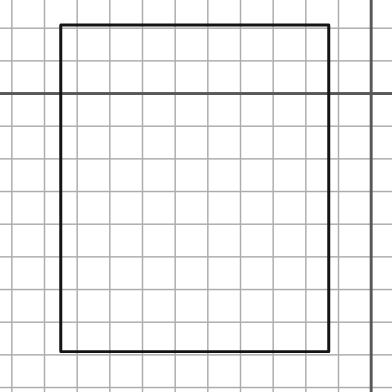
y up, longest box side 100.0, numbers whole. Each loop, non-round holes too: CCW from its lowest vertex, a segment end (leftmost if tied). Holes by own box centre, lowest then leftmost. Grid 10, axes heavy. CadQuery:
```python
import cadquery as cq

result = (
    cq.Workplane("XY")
    .moveTo(-95.0, -79.0)
    .lineTo(-13.0, -79.0)
    .lineTo(-13.0, 21.0)
    .lineTo(-95.0, 21.0)
    .close()
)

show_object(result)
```